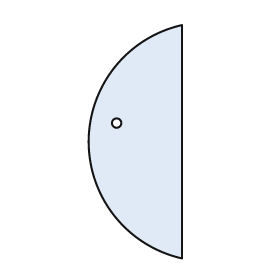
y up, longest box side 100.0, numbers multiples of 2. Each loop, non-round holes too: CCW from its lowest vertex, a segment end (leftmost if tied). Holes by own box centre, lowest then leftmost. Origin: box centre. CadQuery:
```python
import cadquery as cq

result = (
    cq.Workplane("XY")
    .moveTo(20.0, -50.0)
    .lineTo(20.0, 50.0)
    .threePointArc((-20.0, 0.0), (20.0, -50.0))
    .close()
    .moveTo(-8.0, 8.0)
    .circle(2.0)
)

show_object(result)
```